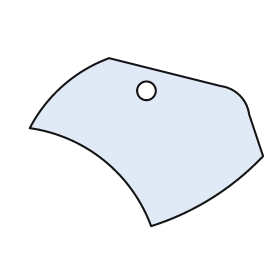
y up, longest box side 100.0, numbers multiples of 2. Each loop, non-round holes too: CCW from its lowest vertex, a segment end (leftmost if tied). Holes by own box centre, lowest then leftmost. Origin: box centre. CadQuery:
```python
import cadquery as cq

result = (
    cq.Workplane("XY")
    .moveTo(2.0, -36.0)
    .threePointArc((28.0, -24.0), (50.0, -6.0))
    .lineTo(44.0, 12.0)
    .threePointArc((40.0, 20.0), (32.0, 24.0))
    .lineTo(-16.0, 36.0)
    .threePointArc((-36.0, 24.0), (-50.0, 6.0))
    .threePointArc((-18.0, -8.0), (2.0, -36.0))
    .close()
    .moveTo(0.0, 22.0)
    .circle(4.0)
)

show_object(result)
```